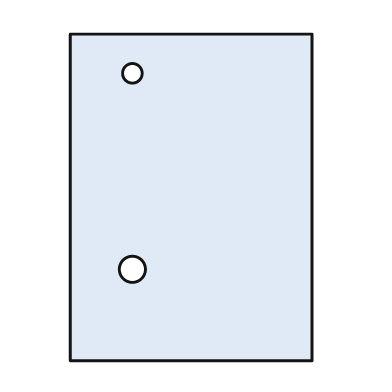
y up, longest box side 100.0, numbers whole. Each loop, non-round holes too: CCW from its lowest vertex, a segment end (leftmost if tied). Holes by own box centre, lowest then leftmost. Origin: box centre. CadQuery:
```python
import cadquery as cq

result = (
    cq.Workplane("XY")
    .moveTo(-37.0, -50.0)
    .lineTo(37.0, -50.0)
    .lineTo(37.0, 50.0)
    .lineTo(-37.0, 50.0)
    .close()
    .moveTo(-18.0, -22.0)
    .circle(4.0)
    .moveTo(-18.0, 38.0)
    .circle(3.0)
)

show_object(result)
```